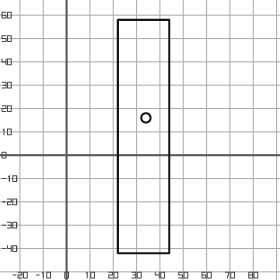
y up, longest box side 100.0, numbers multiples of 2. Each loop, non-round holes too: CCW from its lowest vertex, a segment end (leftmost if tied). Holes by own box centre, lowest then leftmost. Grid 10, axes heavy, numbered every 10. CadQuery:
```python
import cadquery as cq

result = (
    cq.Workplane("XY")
    .moveTo(22.0, -42.0)
    .lineTo(44.0, -42.0)
    .lineTo(44.0, 58.0)
    .lineTo(22.0, 58.0)
    .close()
    .moveTo(34.0, 16.0)
    .circle(2.0)
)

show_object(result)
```